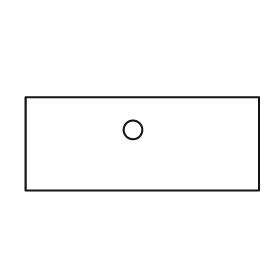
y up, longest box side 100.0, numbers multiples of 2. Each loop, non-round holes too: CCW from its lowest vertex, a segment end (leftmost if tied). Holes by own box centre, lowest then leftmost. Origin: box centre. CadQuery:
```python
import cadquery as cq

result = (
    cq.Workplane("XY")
    .moveTo(-50.0, -20.0)
    .lineTo(50.0, -20.0)
    .lineTo(50.0, 20.0)
    .lineTo(-50.0, 20.0)
    .close()
    .moveTo(-4.0, 6.0)
    .circle(4.0)
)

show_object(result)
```